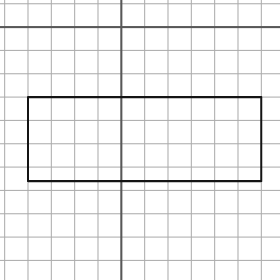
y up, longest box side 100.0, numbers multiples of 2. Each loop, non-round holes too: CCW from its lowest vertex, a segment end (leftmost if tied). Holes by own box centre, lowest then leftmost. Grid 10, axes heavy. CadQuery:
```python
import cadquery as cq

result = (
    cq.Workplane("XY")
    .moveTo(-40.0, -66.0)
    .lineTo(60.0, -66.0)
    .lineTo(60.0, -30.0)
    .lineTo(-40.0, -30.0)
    .close()
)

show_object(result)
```